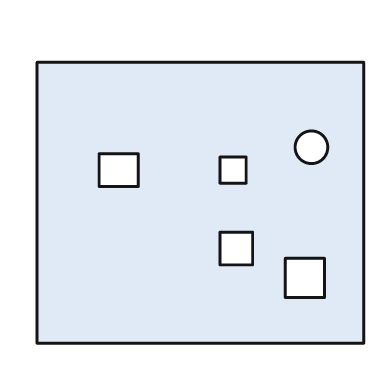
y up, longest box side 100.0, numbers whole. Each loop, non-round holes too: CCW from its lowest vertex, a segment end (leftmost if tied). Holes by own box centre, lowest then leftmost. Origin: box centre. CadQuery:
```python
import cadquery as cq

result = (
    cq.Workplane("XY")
    .moveTo(-50.0, -43.0)
    .lineTo(50.0, -43.0)
    .lineTo(50.0, 43.0)
    .lineTo(-50.0, 43.0)
    .close()
    .moveTo(26.0, -29.0)
    .lineTo(38.0, -29.0)
    .lineTo(38.0, -17.0)
    .lineTo(26.0, -17.0)
    .close()
    .moveTo(6.0, -19.0)
    .lineTo(16.0, -19.0)
    .lineTo(16.0, -9.0)
    .lineTo(6.0, -9.0)
    .close()
    .moveTo(-31.0, 5.0)
    .lineTo(-19.0, 5.0)
    .lineTo(-19.0, 15.0)
    .lineTo(-31.0, 15.0)
    .close()
    .moveTo(6.0, 6.0)
    .lineTo(14.0, 6.0)
    .lineTo(14.0, 14.0)
    .lineTo(6.0, 14.0)
    .close()
    .moveTo(34.0, 17.0)
    .circle(5.0)
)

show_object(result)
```